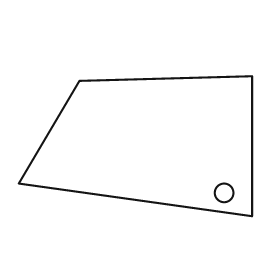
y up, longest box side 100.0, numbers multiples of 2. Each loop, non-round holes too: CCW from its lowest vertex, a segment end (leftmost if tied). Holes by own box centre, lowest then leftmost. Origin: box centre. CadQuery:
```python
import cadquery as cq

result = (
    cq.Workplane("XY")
    .moveTo(50.0, -30.0)
    .lineTo(50.0, 30.0)
    .lineTo(-24.0, 28.0)
    .lineTo(-50.0, -16.0)
    .close()
    .moveTo(38.0, -20.0)
    .circle(4.0)
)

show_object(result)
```